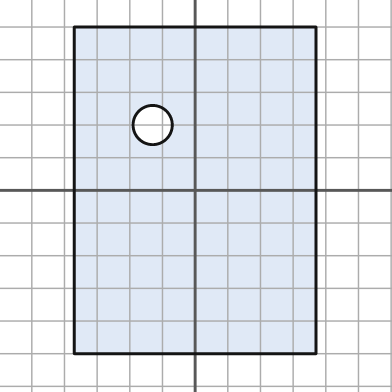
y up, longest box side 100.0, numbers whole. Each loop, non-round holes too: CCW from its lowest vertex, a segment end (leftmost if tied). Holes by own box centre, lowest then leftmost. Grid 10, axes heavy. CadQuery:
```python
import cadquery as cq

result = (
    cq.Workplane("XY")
    .moveTo(-37.0, -50.0)
    .lineTo(37.0, -50.0)
    .lineTo(37.0, 50.0)
    .lineTo(-37.0, 50.0)
    .close()
    .moveTo(-13.0, 20.0)
    .circle(6.0)
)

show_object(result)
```